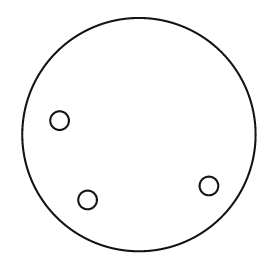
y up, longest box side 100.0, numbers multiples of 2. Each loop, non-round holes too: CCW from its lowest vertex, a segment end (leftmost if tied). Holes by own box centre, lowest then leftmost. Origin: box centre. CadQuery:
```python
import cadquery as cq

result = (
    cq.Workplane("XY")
    .moveTo(0.0, 0.0)
    .circle(50.0)
    .moveTo(-22.0, -28.0)
    .circle(4.0)
    .moveTo(30.0, -22.0)
    .circle(4.0)
    .moveTo(-34.0, 6.0)
    .circle(4.0)
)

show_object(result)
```